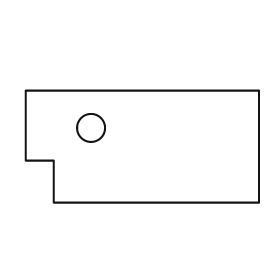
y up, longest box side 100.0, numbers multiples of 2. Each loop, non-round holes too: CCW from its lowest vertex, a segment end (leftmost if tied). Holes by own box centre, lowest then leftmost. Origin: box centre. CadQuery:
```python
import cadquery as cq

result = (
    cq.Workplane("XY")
    .moveTo(-38.0, -24.0)
    .lineTo(50.0, -24.0)
    .lineTo(50.0, 24.0)
    .lineTo(-50.0, 24.0)
    .lineTo(-50.0, -6.0)
    .lineTo(-38.0, -6.0)
    .close()
    .moveTo(-22.0, 8.0)
    .circle(6.0)
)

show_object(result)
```